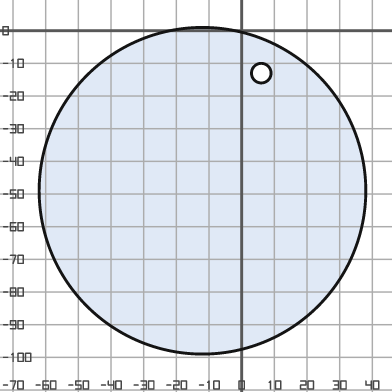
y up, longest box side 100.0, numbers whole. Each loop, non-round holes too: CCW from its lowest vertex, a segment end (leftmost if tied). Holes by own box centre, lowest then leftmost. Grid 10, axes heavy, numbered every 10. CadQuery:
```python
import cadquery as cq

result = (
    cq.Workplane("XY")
    .moveTo(-12.0, -49.0)
    .circle(50.0)
    .moveTo(6.0, -13.0)
    .circle(3.0)
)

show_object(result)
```